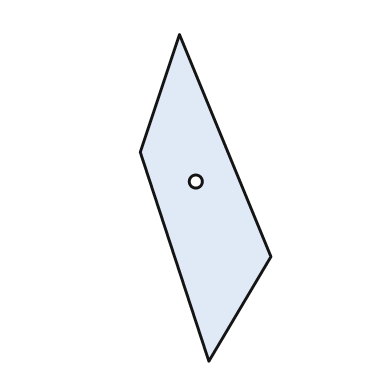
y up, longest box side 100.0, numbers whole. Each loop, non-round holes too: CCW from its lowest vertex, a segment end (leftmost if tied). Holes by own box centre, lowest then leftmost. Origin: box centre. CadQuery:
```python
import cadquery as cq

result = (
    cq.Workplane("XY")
    .moveTo(1.0, -50.0)
    .lineTo(20.0, -18.0)
    .lineTo(-8.0, 50.0)
    .lineTo(-20.0, 14.0)
    .close()
    .moveTo(-3.0, 5.0)
    .circle(2.0)
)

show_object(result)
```